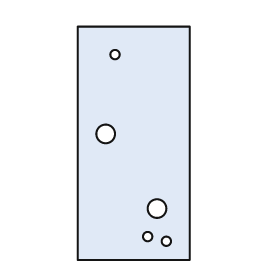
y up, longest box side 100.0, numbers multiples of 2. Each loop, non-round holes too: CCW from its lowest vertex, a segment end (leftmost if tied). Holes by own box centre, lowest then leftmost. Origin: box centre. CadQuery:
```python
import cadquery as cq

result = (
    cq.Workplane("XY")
    .moveTo(-24.0, -50.0)
    .lineTo(24.0, -50.0)
    .lineTo(24.0, 50.0)
    .lineTo(-24.0, 50.0)
    .close()
    .moveTo(14.0, -42.0)
    .circle(2.0)
    .moveTo(6.0, -40.0)
    .circle(2.0)
    .moveTo(10.0, -28.0)
    .circle(4.0)
    .moveTo(-12.0, 4.0)
    .circle(4.0)
    .moveTo(-8.0, 38.0)
    .circle(2.0)
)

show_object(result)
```